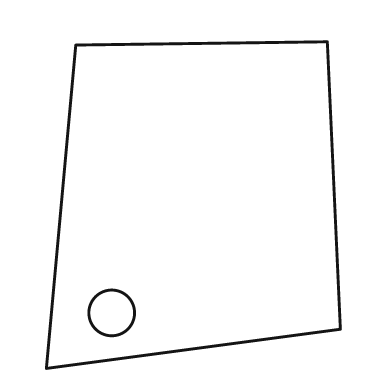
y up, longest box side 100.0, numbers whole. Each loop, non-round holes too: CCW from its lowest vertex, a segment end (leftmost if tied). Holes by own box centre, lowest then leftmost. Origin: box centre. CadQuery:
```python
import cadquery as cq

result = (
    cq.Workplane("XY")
    .moveTo(-45.0, -50.0)
    .lineTo(45.0, -38.0)
    .lineTo(41.0, 50.0)
    .lineTo(-36.0, 49.0)
    .close()
    .moveTo(-25.0, -33.0)
    .circle(7.0)
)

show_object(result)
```